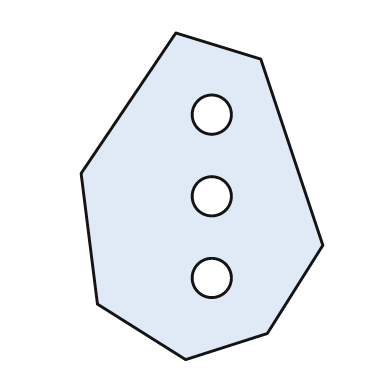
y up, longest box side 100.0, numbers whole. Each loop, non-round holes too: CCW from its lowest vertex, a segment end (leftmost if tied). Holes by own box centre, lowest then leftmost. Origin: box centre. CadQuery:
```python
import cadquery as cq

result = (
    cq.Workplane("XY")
    .moveTo(-5.0, -50.0)
    .lineTo(20.0, -42.0)
    .lineTo(37.0, -15.0)
    .lineTo(18.0, 42.0)
    .lineTo(-8.0, 50.0)
    .lineTo(-37.0, 7.0)
    .lineTo(-32.0, -33.0)
    .close()
    .moveTo(3.0, -25.0)
    .circle(6.0)
    .moveTo(3.0, 0.0)
    .circle(6.0)
    .moveTo(3.0, 25.0)
    .circle(6.0)
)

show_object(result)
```